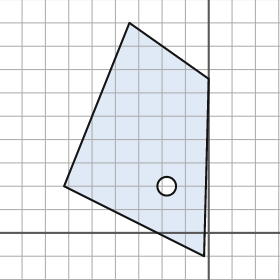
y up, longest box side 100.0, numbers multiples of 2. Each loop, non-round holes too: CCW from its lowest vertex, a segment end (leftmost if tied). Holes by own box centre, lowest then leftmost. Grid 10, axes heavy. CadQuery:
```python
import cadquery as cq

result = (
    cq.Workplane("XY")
    .moveTo(-2.0, -10.0)
    .lineTo(0.0, 66.0)
    .lineTo(-34.0, 90.0)
    .lineTo(-62.0, 20.0)
    .close()
    .moveTo(-18.0, 20.0)
    .circle(4.0)
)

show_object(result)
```